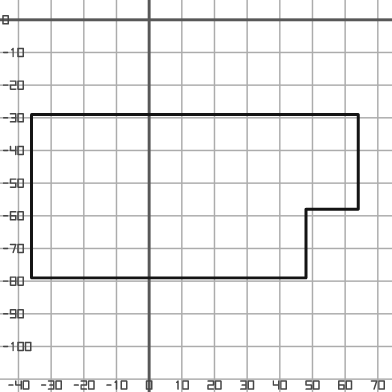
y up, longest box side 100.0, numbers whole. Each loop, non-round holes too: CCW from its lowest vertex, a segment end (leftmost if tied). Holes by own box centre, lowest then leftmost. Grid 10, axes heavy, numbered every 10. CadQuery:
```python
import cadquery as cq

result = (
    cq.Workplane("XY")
    .moveTo(-36.0, -79.0)
    .lineTo(48.0, -79.0)
    .lineTo(48.0, -58.0)
    .lineTo(64.0, -58.0)
    .lineTo(64.0, -29.0)
    .lineTo(-36.0, -29.0)
    .close()
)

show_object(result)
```